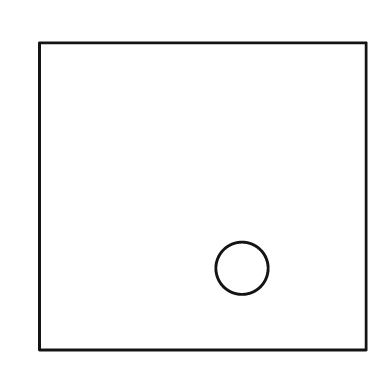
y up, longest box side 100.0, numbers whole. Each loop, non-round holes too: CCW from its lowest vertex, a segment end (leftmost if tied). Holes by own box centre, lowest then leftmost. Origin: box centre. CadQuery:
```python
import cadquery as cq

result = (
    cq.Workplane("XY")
    .moveTo(-50.0, -47.0)
    .lineTo(50.0, -47.0)
    .lineTo(50.0, 47.0)
    .lineTo(-50.0, 47.0)
    .close()
    .moveTo(12.0, -22.0)
    .circle(8.0)
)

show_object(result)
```